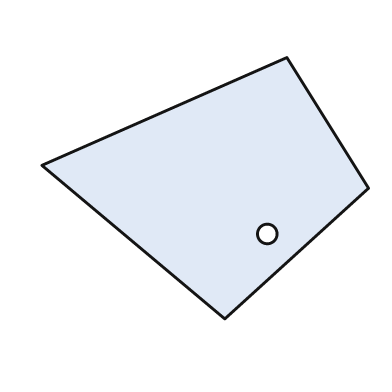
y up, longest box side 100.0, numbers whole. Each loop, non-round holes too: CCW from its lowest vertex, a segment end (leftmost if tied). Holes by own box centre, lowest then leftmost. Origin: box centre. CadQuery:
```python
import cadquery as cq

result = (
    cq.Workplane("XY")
    .moveTo(6.0, -40.0)
    .lineTo(50.0, 0.0)
    .lineTo(25.0, 40.0)
    .lineTo(-50.0, 7.0)
    .close()
    .moveTo(19.0, -14.0)
    .circle(3.0)
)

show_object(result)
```